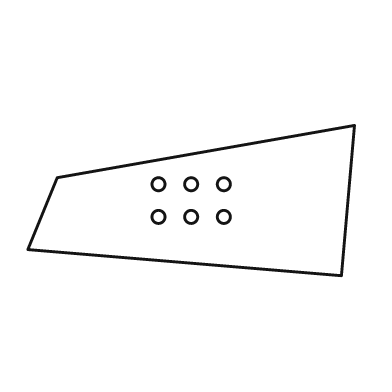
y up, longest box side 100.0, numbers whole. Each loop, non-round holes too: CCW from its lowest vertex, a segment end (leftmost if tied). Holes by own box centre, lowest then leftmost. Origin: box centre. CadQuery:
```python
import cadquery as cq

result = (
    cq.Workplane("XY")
    .moveTo(46.0, -23.0)
    .lineTo(50.0, 23.0)
    .lineTo(-41.0, 7.0)
    .lineTo(-50.0, -15.0)
    .close()
    .moveTo(-10.0, -5.0)
    .circle(2.0)
    .moveTo(0.0, -5.0)
    .circle(2.0)
    .moveTo(10.0, -5.0)
    .circle(2.0)
    .moveTo(-10.0, 5.0)
    .circle(2.0)
    .moveTo(0.0, 5.0)
    .circle(2.0)
    .moveTo(10.0, 5.0)
    .circle(2.0)
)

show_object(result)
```